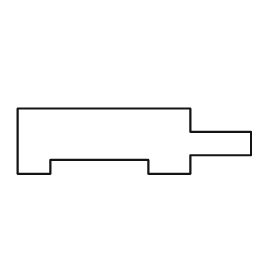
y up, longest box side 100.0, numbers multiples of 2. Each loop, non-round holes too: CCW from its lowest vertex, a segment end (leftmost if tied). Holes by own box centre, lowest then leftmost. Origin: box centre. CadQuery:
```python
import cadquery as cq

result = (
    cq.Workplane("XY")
    .moveTo(-50.0, -14.0)
    .lineTo(-36.0, -14.0)
    .lineTo(-36.0, -8.0)
    .lineTo(6.0, -8.0)
    .lineTo(6.0, -14.0)
    .lineTo(24.0, -14.0)
    .lineTo(24.0, -6.0)
    .lineTo(50.0, -6.0)
    .lineTo(50.0, 4.0)
    .lineTo(24.0, 4.0)
    .lineTo(24.0, 14.0)
    .lineTo(-50.0, 14.0)
    .close()
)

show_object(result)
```